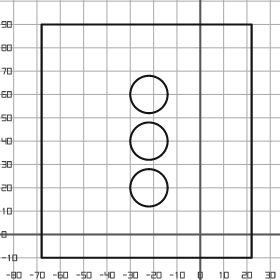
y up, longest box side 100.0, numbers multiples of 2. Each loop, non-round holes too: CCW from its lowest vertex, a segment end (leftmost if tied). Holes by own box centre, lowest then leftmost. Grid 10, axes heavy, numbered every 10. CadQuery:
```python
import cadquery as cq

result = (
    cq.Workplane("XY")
    .moveTo(-68.0, -10.0)
    .lineTo(22.0, -10.0)
    .lineTo(22.0, 90.0)
    .lineTo(-68.0, 90.0)
    .close()
    .moveTo(-22.0, 20.0)
    .circle(8.0)
    .moveTo(-22.0, 40.0)
    .circle(8.0)
    .moveTo(-22.0, 60.0)
    .circle(8.0)
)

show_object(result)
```